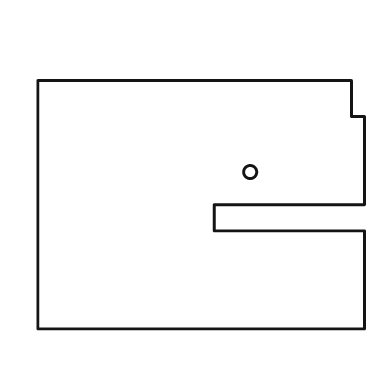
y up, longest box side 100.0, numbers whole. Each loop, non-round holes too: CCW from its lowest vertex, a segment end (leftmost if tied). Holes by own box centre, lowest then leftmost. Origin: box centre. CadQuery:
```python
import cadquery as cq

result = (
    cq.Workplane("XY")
    .moveTo(-50.0, -38.0)
    .lineTo(50.0, -38.0)
    .lineTo(50.0, -8.0)
    .lineTo(4.0, -8.0)
    .lineTo(4.0, 0.0)
    .lineTo(50.0, 0.0)
    .lineTo(50.0, 27.0)
    .lineTo(46.0, 27.0)
    .lineTo(46.0, 38.0)
    .lineTo(-50.0, 38.0)
    .close()
    .moveTo(15.0, 10.0)
    .circle(2.0)
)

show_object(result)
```